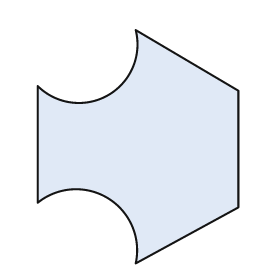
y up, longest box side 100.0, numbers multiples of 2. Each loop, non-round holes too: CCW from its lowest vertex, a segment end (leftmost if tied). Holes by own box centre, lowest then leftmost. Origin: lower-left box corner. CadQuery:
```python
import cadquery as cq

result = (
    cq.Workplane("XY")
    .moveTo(42.0, 0.0)
    .lineTo(86.0, 24.0)
    .lineTo(86.0, 74.0)
    .lineTo(42.0, 100.0)
    .threePointArc((30.0, 72.0), (0.0, 76.0))
    .lineTo(0.0, 26.0)
    .threePointArc((30.0, 28.0), (42.0, 0.0))
    .close()
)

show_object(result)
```